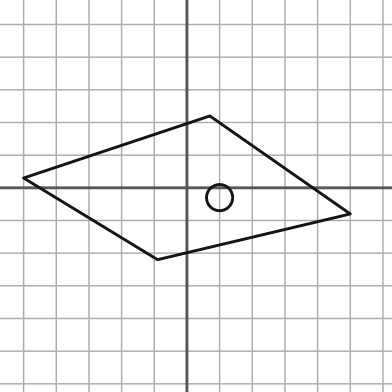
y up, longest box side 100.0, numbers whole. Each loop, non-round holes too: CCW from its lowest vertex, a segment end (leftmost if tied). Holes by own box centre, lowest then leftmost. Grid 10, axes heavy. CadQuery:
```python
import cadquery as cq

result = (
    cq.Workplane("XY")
    .moveTo(-9.0, -22.0)
    .lineTo(50.0, -8.0)
    .lineTo(7.0, 22.0)
    .lineTo(-50.0, 3.0)
    .close()
    .moveTo(10.0, -3.0)
    .circle(4.0)
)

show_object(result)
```